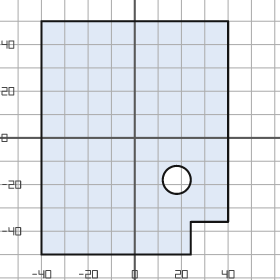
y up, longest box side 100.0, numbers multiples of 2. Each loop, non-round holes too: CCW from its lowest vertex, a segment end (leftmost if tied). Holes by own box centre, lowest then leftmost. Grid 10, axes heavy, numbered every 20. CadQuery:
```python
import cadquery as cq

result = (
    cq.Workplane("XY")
    .moveTo(-40.0, -50.0)
    .lineTo(24.0, -50.0)
    .lineTo(24.0, -36.0)
    .lineTo(40.0, -36.0)
    .lineTo(40.0, 50.0)
    .lineTo(-40.0, 50.0)
    .close()
    .moveTo(18.0, -18.0)
    .circle(6.0)
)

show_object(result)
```